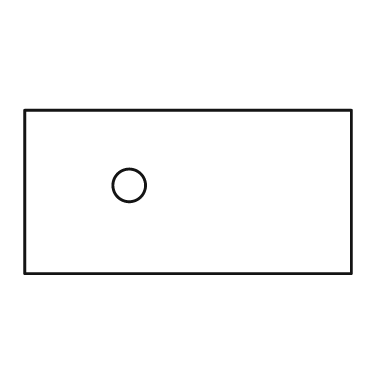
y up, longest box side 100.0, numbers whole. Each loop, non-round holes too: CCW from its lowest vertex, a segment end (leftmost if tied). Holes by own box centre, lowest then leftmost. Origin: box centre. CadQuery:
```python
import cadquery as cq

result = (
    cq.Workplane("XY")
    .moveTo(-50.0, -25.0)
    .lineTo(50.0, -25.0)
    .lineTo(50.0, 25.0)
    .lineTo(-50.0, 25.0)
    .close()
    .moveTo(-18.0, 2.0)
    .circle(5.0)
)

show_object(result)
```